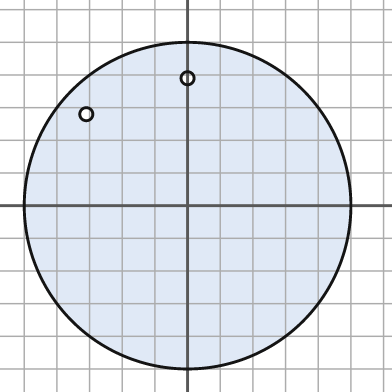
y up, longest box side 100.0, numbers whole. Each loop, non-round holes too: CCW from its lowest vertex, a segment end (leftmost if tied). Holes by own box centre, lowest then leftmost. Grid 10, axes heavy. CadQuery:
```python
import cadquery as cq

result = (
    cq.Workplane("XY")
    .moveTo(0.0, 0.0)
    .circle(50.0)
    .moveTo(-31.0, 28.0)
    .circle(2.0)
    .moveTo(0.0, 39.0)
    .circle(2.0)
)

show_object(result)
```